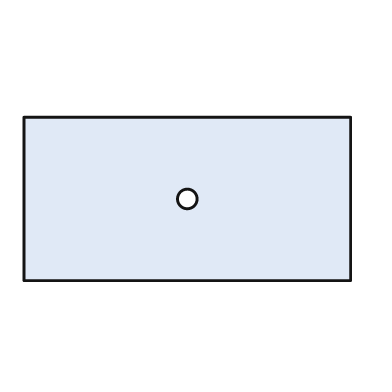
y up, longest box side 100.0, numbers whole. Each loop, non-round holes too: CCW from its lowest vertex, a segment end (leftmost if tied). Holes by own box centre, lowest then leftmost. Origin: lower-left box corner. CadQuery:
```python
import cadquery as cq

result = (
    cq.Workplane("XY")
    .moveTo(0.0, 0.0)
    .lineTo(100.0, 0.0)
    .lineTo(100.0, 50.0)
    .lineTo(0.0, 50.0)
    .close()
    .moveTo(50.0, 25.0)
    .circle(3.0)
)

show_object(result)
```